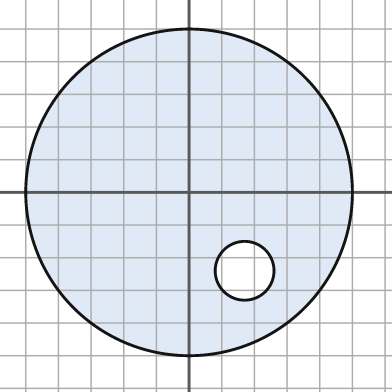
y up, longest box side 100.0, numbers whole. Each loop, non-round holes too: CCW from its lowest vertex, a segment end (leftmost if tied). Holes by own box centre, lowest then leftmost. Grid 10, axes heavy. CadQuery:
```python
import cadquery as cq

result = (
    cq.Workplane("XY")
    .moveTo(0.0, 0.0)
    .circle(50.0)
    .moveTo(17.0, -24.0)
    .circle(9.0)
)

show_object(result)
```